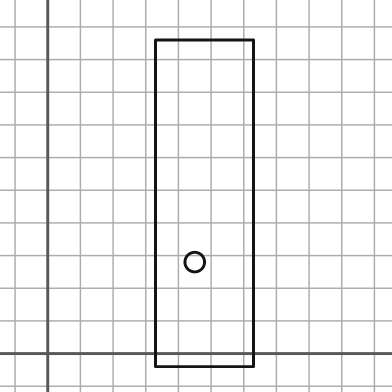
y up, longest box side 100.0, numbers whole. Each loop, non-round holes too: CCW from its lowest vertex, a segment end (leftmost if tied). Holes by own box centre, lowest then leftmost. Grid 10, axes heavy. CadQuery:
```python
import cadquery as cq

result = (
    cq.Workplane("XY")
    .moveTo(33.0, -4.0)
    .lineTo(63.0, -4.0)
    .lineTo(63.0, 96.0)
    .lineTo(33.0, 96.0)
    .close()
    .moveTo(45.0, 28.0)
    .circle(3.0)
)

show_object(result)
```